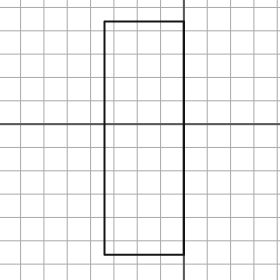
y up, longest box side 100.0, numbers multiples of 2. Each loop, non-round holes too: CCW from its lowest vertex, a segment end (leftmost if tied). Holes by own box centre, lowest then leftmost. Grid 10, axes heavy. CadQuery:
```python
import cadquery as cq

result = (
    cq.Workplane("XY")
    .moveTo(-34.0, -56.0)
    .lineTo(0.0, -56.0)
    .lineTo(0.0, 44.0)
    .lineTo(-34.0, 44.0)
    .close()
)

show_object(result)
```